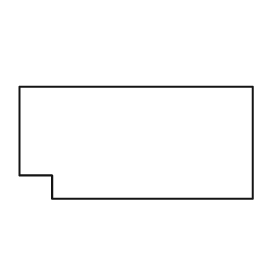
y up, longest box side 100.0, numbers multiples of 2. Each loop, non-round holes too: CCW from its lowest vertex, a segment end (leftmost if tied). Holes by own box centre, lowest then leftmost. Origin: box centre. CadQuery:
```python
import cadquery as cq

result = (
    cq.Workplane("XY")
    .moveTo(-36.0, -24.0)
    .lineTo(50.0, -24.0)
    .lineTo(50.0, 24.0)
    .lineTo(-50.0, 24.0)
    .lineTo(-50.0, -14.0)
    .lineTo(-36.0, -14.0)
    .close()
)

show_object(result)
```